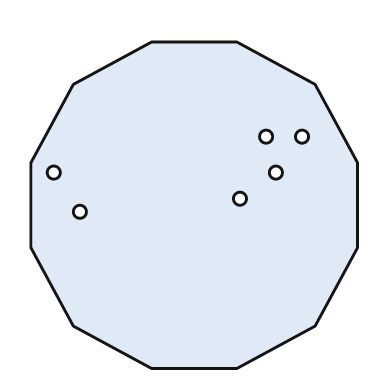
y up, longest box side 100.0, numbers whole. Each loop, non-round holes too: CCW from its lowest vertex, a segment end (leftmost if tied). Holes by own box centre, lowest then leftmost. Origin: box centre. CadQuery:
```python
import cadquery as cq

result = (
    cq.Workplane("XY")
    .moveTo(-13.0, -50.0)
    .lineTo(13.0, -50.0)
    .lineTo(37.0, -37.0)
    .lineTo(50.0, -13.0)
    .lineTo(50.0, 13.0)
    .lineTo(37.0, 37.0)
    .lineTo(13.0, 50.0)
    .lineTo(-13.0, 50.0)
    .lineTo(-37.0, 37.0)
    .lineTo(-50.0, 13.0)
    .lineTo(-50.0, -13.0)
    .lineTo(-37.0, -37.0)
    .close()
    .moveTo(-35.0, -2.0)
    .circle(2.0)
    .moveTo(14.0, 2.0)
    .circle(2.0)
    .moveTo(-43.0, 10.0)
    .circle(2.0)
    .moveTo(25.0, 10.0)
    .circle(2.0)
    .moveTo(22.0, 21.0)
    .circle(2.0)
    .moveTo(33.0, 21.0)
    .circle(2.0)
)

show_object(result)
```